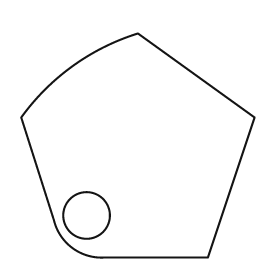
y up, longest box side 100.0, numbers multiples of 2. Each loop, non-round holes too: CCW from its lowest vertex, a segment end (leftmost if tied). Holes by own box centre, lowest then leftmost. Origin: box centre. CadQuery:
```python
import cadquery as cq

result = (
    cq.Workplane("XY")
    .moveTo(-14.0, -48.0)
    .lineTo(30.0, -48.0)
    .lineTo(50.0, 12.0)
    .lineTo(0.0, 48.0)
    .threePointArc((-28.0, 34.0), (-50.0, 12.0))
    .lineTo(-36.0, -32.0)
    .threePointArc((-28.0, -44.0), (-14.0, -48.0))
    .close()
    .moveTo(-22.0, -30.0)
    .circle(10.0)
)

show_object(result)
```